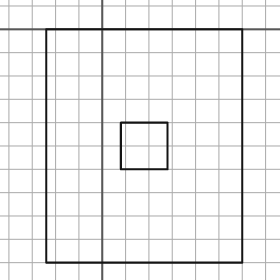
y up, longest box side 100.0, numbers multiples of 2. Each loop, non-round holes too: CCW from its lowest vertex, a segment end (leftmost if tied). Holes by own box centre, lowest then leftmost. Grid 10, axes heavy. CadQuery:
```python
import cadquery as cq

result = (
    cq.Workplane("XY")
    .moveTo(-24.0, -100.0)
    .lineTo(60.0, -100.0)
    .lineTo(60.0, 0.0)
    .lineTo(-24.0, 0.0)
    .close()
    .moveTo(8.0, -60.0)
    .lineTo(28.0, -60.0)
    .lineTo(28.0, -40.0)
    .lineTo(8.0, -40.0)
    .close()
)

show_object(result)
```